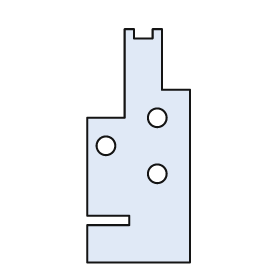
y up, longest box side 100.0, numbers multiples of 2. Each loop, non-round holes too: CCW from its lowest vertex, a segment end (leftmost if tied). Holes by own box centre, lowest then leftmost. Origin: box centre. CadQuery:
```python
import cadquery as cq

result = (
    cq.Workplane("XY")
    .moveTo(-22.0, -50.0)
    .lineTo(22.0, -50.0)
    .lineTo(22.0, 24.0)
    .lineTo(10.0, 24.0)
    .lineTo(10.0, 50.0)
    .lineTo(6.0, 50.0)
    .lineTo(6.0, 46.0)
    .lineTo(-2.0, 46.0)
    .lineTo(-2.0, 50.0)
    .lineTo(-6.0, 50.0)
    .lineTo(-6.0, 12.0)
    .lineTo(-22.0, 12.0)
    .lineTo(-22.0, -30.0)
    .lineTo(-4.0, -30.0)
    .lineTo(-4.0, -34.0)
    .lineTo(-22.0, -34.0)
    .close()
    .moveTo(8.0, -12.0)
    .circle(4.0)
    .moveTo(-14.0, 0.0)
    .circle(4.0)
    .moveTo(8.0, 12.0)
    .circle(4.0)
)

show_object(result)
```